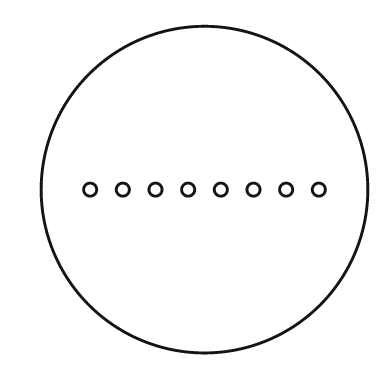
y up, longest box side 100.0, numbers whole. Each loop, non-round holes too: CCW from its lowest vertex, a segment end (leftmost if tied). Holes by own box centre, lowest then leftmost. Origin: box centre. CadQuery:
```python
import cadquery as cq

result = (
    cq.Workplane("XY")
    .moveTo(0.0, 0.0)
    .circle(50.0)
    .moveTo(-35.0, 0.0)
    .circle(2.0)
    .moveTo(-25.0, 0.0)
    .circle(2.0)
    .moveTo(-15.0, 0.0)
    .circle(2.0)
    .moveTo(-5.0, 0.0)
    .circle(2.0)
    .moveTo(5.0, 0.0)
    .circle(2.0)
    .moveTo(15.0, 0.0)
    .circle(2.0)
    .moveTo(25.0, 0.0)
    .circle(2.0)
    .moveTo(35.0, 0.0)
    .circle(2.0)
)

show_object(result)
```